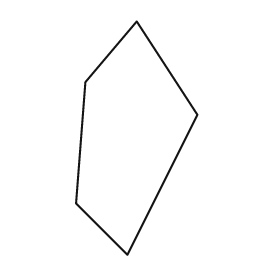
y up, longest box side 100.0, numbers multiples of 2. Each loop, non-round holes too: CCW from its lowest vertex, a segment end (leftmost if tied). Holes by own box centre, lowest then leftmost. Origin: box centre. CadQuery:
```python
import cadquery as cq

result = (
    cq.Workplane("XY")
    .moveTo(-4.0, -50.0)
    .lineTo(26.0, 10.0)
    .lineTo(0.0, 50.0)
    .lineTo(-22.0, 24.0)
    .lineTo(-26.0, -28.0)
    .close()
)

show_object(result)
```